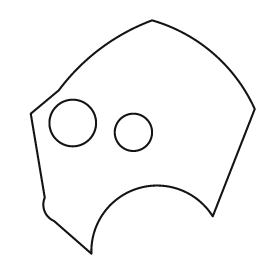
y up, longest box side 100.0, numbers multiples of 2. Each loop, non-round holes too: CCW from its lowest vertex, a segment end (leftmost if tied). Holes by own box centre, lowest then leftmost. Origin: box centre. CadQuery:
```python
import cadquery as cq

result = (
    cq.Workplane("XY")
    .moveTo(-22.0, -50.0)
    .threePointArc((-2.0, -22.0), (30.0, -34.0))
    .lineTo(48.0, 12.0)
    .threePointArc((30.0, 36.0), (4.0, 50.0))
    .threePointArc((-18.0, 38.0), (-36.0, 20.0))
    .lineTo(-48.0, 10.0)
    .lineTo(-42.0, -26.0)
    .threePointArc((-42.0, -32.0), (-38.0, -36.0))
    .close()
    .moveTo(-4.0, 2.0)
    .circle(8.0)
    .moveTo(-30.0, 6.0)
    .circle(10.0)
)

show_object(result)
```